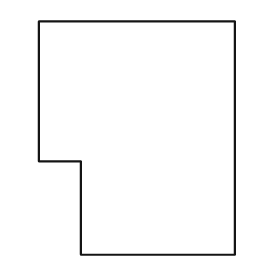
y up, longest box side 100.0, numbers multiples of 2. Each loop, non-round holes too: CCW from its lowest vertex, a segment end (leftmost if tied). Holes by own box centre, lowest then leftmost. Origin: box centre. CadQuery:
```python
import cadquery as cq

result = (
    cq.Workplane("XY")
    .moveTo(-24.0, -50.0)
    .lineTo(42.0, -50.0)
    .lineTo(42.0, 50.0)
    .lineTo(-42.0, 50.0)
    .lineTo(-42.0, -10.0)
    .lineTo(-24.0, -10.0)
    .close()
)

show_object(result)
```